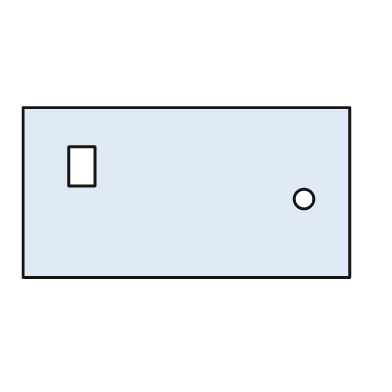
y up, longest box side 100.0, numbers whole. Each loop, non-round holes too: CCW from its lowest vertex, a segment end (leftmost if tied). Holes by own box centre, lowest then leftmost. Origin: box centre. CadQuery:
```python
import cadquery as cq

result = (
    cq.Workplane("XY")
    .moveTo(-50.0, -26.0)
    .lineTo(50.0, -26.0)
    .lineTo(50.0, 26.0)
    .lineTo(-50.0, 26.0)
    .close()
    .moveTo(36.0, -2.0)
    .circle(3.0)
    .moveTo(-36.0, 2.0)
    .lineTo(-28.0, 2.0)
    .lineTo(-28.0, 14.0)
    .lineTo(-36.0, 14.0)
    .close()
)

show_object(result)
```